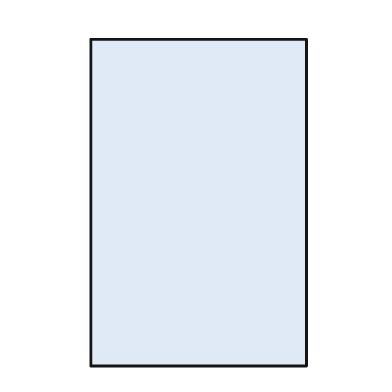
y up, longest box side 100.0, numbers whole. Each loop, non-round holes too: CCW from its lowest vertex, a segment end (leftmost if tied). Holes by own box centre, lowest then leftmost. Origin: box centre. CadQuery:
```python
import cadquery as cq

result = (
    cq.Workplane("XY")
    .moveTo(-33.0, -50.0)
    .lineTo(33.0, -50.0)
    .lineTo(33.0, 50.0)
    .lineTo(-33.0, 50.0)
    .close()
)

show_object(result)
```